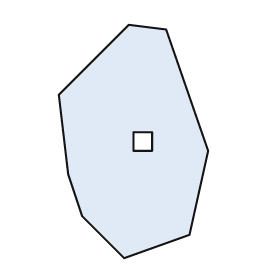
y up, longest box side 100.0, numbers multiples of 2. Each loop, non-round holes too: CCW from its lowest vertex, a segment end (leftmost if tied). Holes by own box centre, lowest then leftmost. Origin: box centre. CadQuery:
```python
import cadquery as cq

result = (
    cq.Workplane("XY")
    .moveTo(-4.0, -50.0)
    .lineTo(24.0, -40.0)
    .lineTo(32.0, -4.0)
    .lineTo(14.0, 48.0)
    .lineTo(-2.0, 50.0)
    .lineTo(-32.0, 20.0)
    .lineTo(-28.0, -14.0)
    .lineTo(-22.0, -32.0)
    .close()
    .moveTo(0.0, -4.0)
    .lineTo(8.0, -4.0)
    .lineTo(8.0, 4.0)
    .lineTo(0.0, 4.0)
    .close()
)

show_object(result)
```